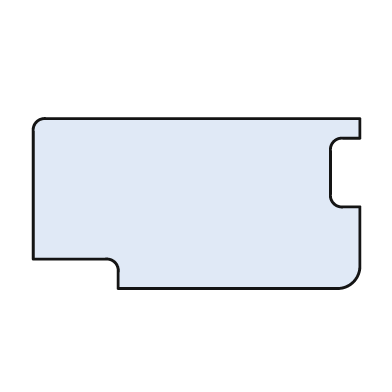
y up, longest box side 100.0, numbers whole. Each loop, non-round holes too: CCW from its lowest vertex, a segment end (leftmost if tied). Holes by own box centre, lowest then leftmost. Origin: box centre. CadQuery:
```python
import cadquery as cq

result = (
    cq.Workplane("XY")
    .moveTo(-24.0, -26.0)
    .lineTo(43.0, -26.0)
    .threePointArc((48.0, -24.0), (50.0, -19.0))
    .lineTo(50.0, -1.0)
    .lineTo(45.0, -1.0)
    .threePointArc((42.0, 0.0), (41.0, 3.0))
    .lineTo(41.0, 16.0)
    .threePointArc((42.0, 19.0), (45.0, 20.0))
    .lineTo(50.0, 20.0)
    .lineTo(50.0, 26.0)
    .lineTo(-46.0, 26.0)
    .threePointArc((-49.0, 25.0), (-50.0, 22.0))
    .lineTo(-50.0, -17.0)
    .lineTo(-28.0, -17.0)
    .threePointArc((-25.0, -18.0), (-24.0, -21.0))
    .close()
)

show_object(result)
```